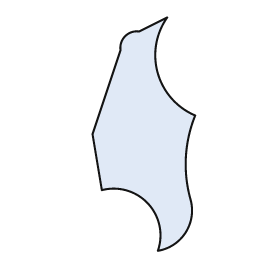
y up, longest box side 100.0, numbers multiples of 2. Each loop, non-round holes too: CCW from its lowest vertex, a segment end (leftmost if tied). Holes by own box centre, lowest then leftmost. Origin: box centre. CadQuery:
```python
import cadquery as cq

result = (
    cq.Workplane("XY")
    .moveTo(6.0, -50.0)
    .threePointArc((18.0, -42.0), (20.0, -28.0))
    .threePointArc((18.0, -10.0), (22.0, 8.0))
    .threePointArc((6.0, 26.0), (10.0, 50.0))
    .lineTo(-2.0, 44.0)
    .threePointArc((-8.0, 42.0), (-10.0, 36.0))
    .lineTo(-22.0, 0.0)
    .lineTo(-18.0, -24.0)
    .threePointArc((2.0, -30.0), (6.0, -50.0))
    .close()
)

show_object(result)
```